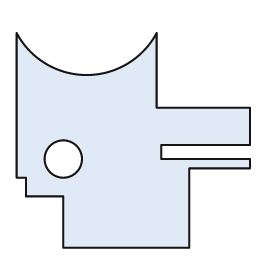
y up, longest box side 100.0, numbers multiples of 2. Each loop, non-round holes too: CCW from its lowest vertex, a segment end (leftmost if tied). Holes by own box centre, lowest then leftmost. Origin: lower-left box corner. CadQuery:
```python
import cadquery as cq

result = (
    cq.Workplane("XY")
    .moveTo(20.0, 0.0)
    .lineTo(74.0, 0.0)
    .lineTo(74.0, 34.0)
    .lineTo(100.0, 34.0)
    .lineTo(100.0, 38.0)
    .lineTo(62.0, 38.0)
    .lineTo(62.0, 44.0)
    .lineTo(100.0, 44.0)
    .lineTo(100.0, 60.0)
    .lineTo(60.0, 60.0)
    .lineTo(60.0, 92.0)
    .threePointArc((30.0, 74.0), (0.0, 92.0))
    .lineTo(0.0, 30.0)
    .lineTo(4.0, 30.0)
    .lineTo(4.0, 22.0)
    .lineTo(20.0, 22.0)
    .close()
    .moveTo(20.0, 38.0)
    .circle(8.0)
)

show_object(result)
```